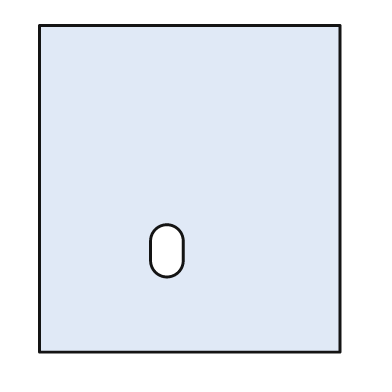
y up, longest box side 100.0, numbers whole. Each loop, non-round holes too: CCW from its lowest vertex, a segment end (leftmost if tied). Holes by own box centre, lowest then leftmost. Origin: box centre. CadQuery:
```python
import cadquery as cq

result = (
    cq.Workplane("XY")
    .moveTo(-46.0, -50.0)
    .lineTo(46.0, -50.0)
    .lineTo(46.0, 50.0)
    .lineTo(-46.0, 50.0)
    .close()
    .moveTo(-12.0, -22.0)
    .threePointArc((-7.0, -27.0), (-2.0, -22.0))
    .lineTo(-2.0, -16.0)
    .threePointArc((-7.0, -11.0), (-12.0, -16.0))
    .close()
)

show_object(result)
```